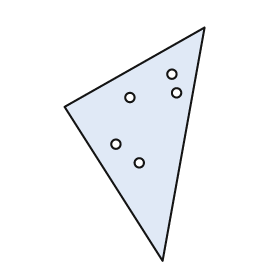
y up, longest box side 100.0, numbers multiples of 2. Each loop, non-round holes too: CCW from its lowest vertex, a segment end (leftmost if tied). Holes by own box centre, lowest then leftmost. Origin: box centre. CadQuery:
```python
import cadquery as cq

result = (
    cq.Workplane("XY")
    .moveTo(12.0, -50.0)
    .lineTo(30.0, 50.0)
    .lineTo(-30.0, 16.0)
    .close()
    .moveTo(2.0, -8.0)
    .circle(2.0)
    .moveTo(-8.0, 0.0)
    .circle(2.0)
    .moveTo(-2.0, 20.0)
    .circle(2.0)
    .moveTo(18.0, 22.0)
    .circle(2.0)
    .moveTo(16.0, 30.0)
    .circle(2.0)
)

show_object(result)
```